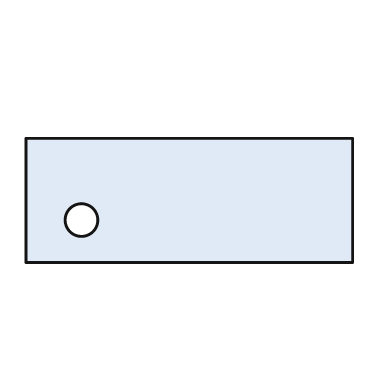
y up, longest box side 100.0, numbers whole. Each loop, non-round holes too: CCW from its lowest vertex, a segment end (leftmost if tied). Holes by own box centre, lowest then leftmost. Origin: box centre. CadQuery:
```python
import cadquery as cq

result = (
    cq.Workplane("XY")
    .moveTo(-50.0, -19.0)
    .lineTo(50.0, -19.0)
    .lineTo(50.0, 19.0)
    .lineTo(-50.0, 19.0)
    .close()
    .moveTo(-33.0, -6.0)
    .circle(5.0)
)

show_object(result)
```